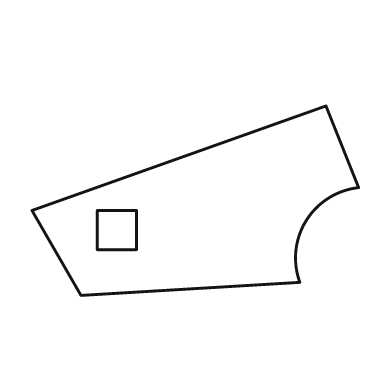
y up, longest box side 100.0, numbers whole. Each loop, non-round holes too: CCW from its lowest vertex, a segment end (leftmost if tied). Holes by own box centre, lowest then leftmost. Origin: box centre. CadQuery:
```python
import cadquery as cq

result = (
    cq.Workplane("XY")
    .moveTo(-35.0, -29.0)
    .lineTo(32.0, -25.0)
    .threePointArc((34.0, -6.0), (50.0, 4.0))
    .lineTo(40.0, 29.0)
    .lineTo(-50.0, -3.0)
    .close()
    .moveTo(-30.0, -15.0)
    .lineTo(-18.0, -15.0)
    .lineTo(-18.0, -3.0)
    .lineTo(-30.0, -3.0)
    .close()
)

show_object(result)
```